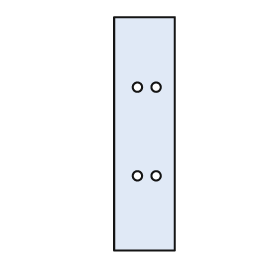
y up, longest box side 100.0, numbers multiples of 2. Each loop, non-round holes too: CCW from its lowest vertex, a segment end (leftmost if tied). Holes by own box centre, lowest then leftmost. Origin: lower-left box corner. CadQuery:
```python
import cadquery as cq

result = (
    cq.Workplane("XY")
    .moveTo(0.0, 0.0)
    .lineTo(26.0, 0.0)
    .lineTo(26.0, 100.0)
    .lineTo(0.0, 100.0)
    .close()
    .moveTo(10.0, 32.0)
    .circle(2.0)
    .moveTo(18.0, 32.0)
    .circle(2.0)
    .moveTo(10.0, 70.0)
    .circle(2.0)
    .moveTo(18.0, 70.0)
    .circle(2.0)
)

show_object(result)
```